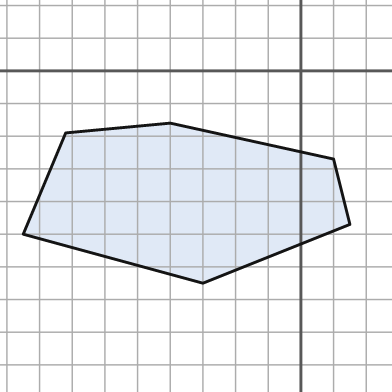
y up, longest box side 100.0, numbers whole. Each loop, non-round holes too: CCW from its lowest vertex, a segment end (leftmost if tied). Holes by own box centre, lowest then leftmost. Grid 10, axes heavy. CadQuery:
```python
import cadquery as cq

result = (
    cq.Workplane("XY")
    .moveTo(-30.0, -65.0)
    .lineTo(15.0, -47.0)
    .lineTo(10.0, -27.0)
    .lineTo(-40.0, -16.0)
    .lineTo(-72.0, -19.0)
    .lineTo(-85.0, -50.0)
    .close()
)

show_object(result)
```